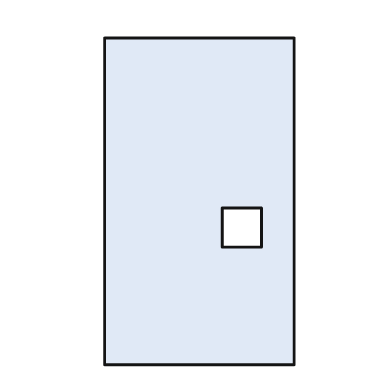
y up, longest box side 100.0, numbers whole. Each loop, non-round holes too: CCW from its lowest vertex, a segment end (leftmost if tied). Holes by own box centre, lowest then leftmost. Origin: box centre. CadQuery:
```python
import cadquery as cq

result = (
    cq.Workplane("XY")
    .moveTo(-29.0, -50.0)
    .lineTo(29.0, -50.0)
    .lineTo(29.0, 50.0)
    .lineTo(-29.0, 50.0)
    .close()
    .moveTo(7.0, -14.0)
    .lineTo(19.0, -14.0)
    .lineTo(19.0, -2.0)
    .lineTo(7.0, -2.0)
    .close()
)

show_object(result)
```